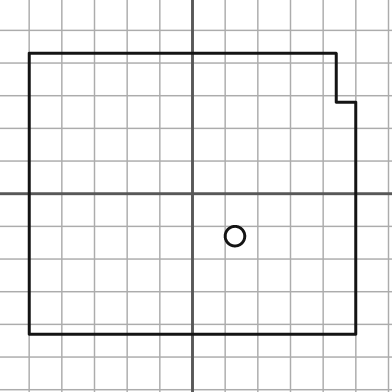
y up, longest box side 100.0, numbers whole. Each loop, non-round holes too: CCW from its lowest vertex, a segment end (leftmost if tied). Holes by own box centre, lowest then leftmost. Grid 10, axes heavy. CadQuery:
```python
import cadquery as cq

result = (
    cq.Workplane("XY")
    .moveTo(-50.0, -43.0)
    .lineTo(50.0, -43.0)
    .lineTo(50.0, 28.0)
    .lineTo(44.0, 28.0)
    .lineTo(44.0, 43.0)
    .lineTo(-50.0, 43.0)
    .close()
    .moveTo(13.0, -13.0)
    .circle(3.0)
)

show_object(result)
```